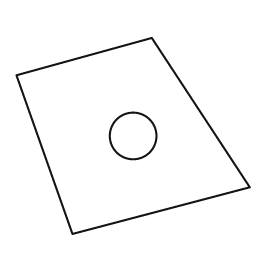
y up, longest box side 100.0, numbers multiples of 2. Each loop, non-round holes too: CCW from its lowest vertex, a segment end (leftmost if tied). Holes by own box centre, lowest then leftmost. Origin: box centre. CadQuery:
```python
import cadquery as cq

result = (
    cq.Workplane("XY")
    .moveTo(-26.0, -42.0)
    .lineTo(50.0, -22.0)
    .lineTo(8.0, 42.0)
    .lineTo(-50.0, 26.0)
    .close()
    .moveTo(0.0, 0.0)
    .circle(10.0)
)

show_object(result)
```